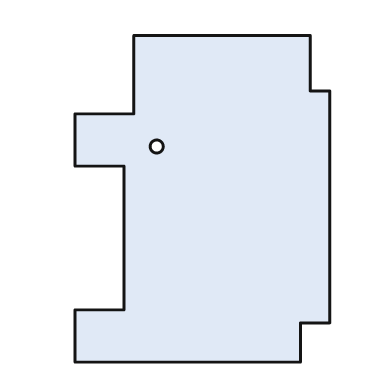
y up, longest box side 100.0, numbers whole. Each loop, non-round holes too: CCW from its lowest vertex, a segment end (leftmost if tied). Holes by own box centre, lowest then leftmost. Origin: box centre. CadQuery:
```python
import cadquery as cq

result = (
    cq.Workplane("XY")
    .moveTo(-39.0, -50.0)
    .lineTo(30.0, -50.0)
    .lineTo(30.0, -38.0)
    .lineTo(39.0, -38.0)
    .lineTo(39.0, 33.0)
    .lineTo(33.0, 33.0)
    .lineTo(33.0, 50.0)
    .lineTo(-21.0, 50.0)
    .lineTo(-21.0, 26.0)
    .lineTo(-39.0, 26.0)
    .lineTo(-39.0, 10.0)
    .lineTo(-24.0, 10.0)
    .lineTo(-24.0, -34.0)
    .lineTo(-39.0, -34.0)
    .close()
    .moveTo(-14.0, 16.0)
    .circle(2.0)
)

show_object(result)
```